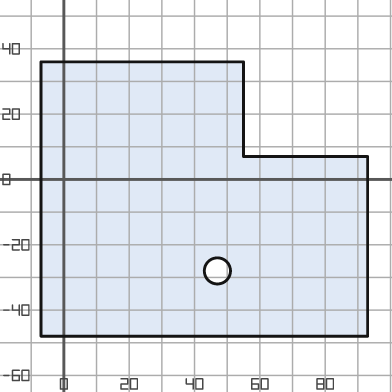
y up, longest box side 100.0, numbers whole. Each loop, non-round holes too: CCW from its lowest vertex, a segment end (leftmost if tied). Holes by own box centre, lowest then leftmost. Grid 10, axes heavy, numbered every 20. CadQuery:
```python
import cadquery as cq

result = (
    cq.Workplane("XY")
    .moveTo(-7.0, -48.0)
    .lineTo(93.0, -48.0)
    .lineTo(93.0, 7.0)
    .lineTo(55.0, 7.0)
    .lineTo(55.0, 36.0)
    .lineTo(-7.0, 36.0)
    .close()
    .moveTo(47.0, -28.0)
    .circle(4.0)
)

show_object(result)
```